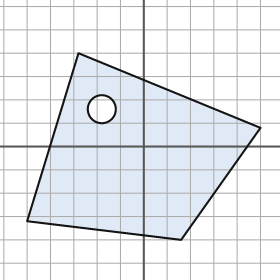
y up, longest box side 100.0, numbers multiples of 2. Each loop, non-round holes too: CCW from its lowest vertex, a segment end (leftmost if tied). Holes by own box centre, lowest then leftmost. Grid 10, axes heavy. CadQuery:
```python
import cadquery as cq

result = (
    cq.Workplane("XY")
    .moveTo(16.0, -40.0)
    .lineTo(50.0, 8.0)
    .lineTo(-28.0, 40.0)
    .lineTo(-50.0, -32.0)
    .close()
    .moveTo(-18.0, 16.0)
    .circle(6.0)
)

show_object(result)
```